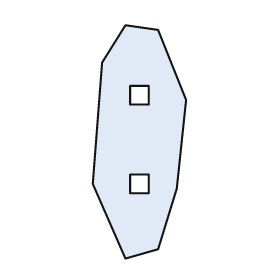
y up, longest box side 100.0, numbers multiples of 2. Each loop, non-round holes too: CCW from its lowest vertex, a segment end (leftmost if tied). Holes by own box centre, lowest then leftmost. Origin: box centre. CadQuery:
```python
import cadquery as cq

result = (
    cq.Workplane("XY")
    .moveTo(-6.0, -50.0)
    .lineTo(8.0, -46.0)
    .lineTo(16.0, -20.0)
    .lineTo(20.0, 18.0)
    .lineTo(8.0, 48.0)
    .lineTo(-6.0, 50.0)
    .lineTo(-16.0, 34.0)
    .lineTo(-20.0, -18.0)
    .close()
    .moveTo(-4.0, -22.0)
    .lineTo(4.0, -22.0)
    .lineTo(4.0, -14.0)
    .lineTo(-4.0, -14.0)
    .close()
    .moveTo(-4.0, 16.0)
    .lineTo(4.0, 16.0)
    .lineTo(4.0, 24.0)
    .lineTo(-4.0, 24.0)
    .close()
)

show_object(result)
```